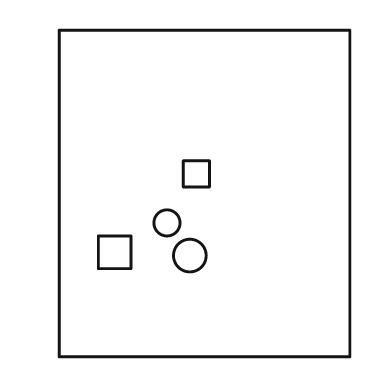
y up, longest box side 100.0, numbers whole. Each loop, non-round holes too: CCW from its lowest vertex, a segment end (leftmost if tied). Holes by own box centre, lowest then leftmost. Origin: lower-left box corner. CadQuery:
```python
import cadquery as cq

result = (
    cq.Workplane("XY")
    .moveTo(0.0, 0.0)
    .lineTo(89.0, 0.0)
    .lineTo(89.0, 100.0)
    .lineTo(0.0, 100.0)
    .close()
    .moveTo(40.0, 31.0)
    .circle(5.0)
    .moveTo(12.0, 27.0)
    .lineTo(22.0, 27.0)
    .lineTo(22.0, 37.0)
    .lineTo(12.0, 37.0)
    .close()
    .moveTo(33.0, 41.0)
    .circle(4.0)
    .moveTo(38.0, 52.0)
    .lineTo(46.0, 52.0)
    .lineTo(46.0, 60.0)
    .lineTo(38.0, 60.0)
    .close()
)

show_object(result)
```